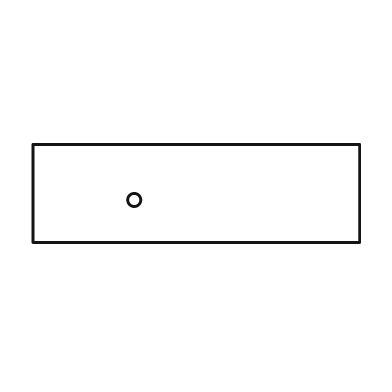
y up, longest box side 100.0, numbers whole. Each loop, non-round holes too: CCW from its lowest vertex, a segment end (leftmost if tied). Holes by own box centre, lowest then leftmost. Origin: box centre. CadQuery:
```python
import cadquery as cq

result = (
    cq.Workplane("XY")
    .moveTo(-50.0, -15.0)
    .lineTo(50.0, -15.0)
    .lineTo(50.0, 15.0)
    .lineTo(-50.0, 15.0)
    .close()
    .moveTo(-19.0, -2.0)
    .circle(2.0)
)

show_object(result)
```